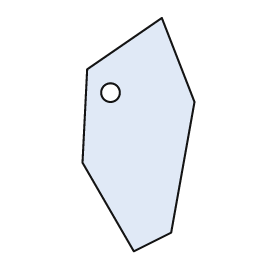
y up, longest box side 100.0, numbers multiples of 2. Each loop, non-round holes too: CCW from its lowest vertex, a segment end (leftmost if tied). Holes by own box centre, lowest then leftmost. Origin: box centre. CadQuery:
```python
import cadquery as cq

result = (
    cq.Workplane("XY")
    .moveTo(-2.0, -50.0)
    .lineTo(14.0, -42.0)
    .lineTo(24.0, 14.0)
    .lineTo(10.0, 50.0)
    .lineTo(-22.0, 28.0)
    .lineTo(-24.0, -12.0)
    .close()
    .moveTo(-12.0, 18.0)
    .circle(4.0)
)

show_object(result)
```